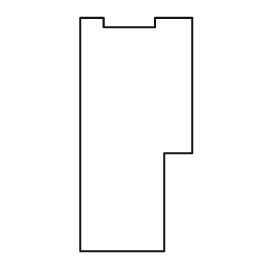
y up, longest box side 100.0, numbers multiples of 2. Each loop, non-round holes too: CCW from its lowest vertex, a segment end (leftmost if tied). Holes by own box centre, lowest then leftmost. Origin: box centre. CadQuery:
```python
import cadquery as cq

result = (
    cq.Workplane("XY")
    .moveTo(-24.0, -50.0)
    .lineTo(12.0, -50.0)
    .lineTo(12.0, -8.0)
    .lineTo(24.0, -8.0)
    .lineTo(24.0, 50.0)
    .lineTo(8.0, 50.0)
    .lineTo(8.0, 46.0)
    .lineTo(-14.0, 46.0)
    .lineTo(-14.0, 50.0)
    .lineTo(-24.0, 50.0)
    .close()
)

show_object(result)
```